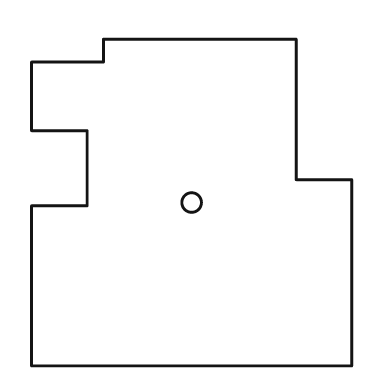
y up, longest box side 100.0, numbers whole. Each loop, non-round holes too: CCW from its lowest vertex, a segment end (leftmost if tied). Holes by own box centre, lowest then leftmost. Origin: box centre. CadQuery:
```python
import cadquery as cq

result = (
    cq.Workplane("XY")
    .moveTo(-49.0, -50.0)
    .lineTo(49.0, -50.0)
    .lineTo(49.0, 7.0)
    .lineTo(32.0, 7.0)
    .lineTo(32.0, 50.0)
    .lineTo(-27.0, 50.0)
    .lineTo(-27.0, 43.0)
    .lineTo(-49.0, 43.0)
    .lineTo(-49.0, 22.0)
    .lineTo(-32.0, 22.0)
    .lineTo(-32.0, -1.0)
    .lineTo(-49.0, -1.0)
    .close()
    .moveTo(0.0, 0.0)
    .circle(3.0)
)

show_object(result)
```